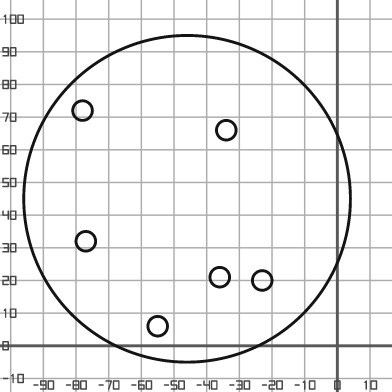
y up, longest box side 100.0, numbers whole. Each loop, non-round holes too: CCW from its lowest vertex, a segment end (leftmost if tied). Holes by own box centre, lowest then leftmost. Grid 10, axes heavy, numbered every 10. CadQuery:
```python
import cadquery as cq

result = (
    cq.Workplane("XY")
    .moveTo(-46.0, 45.0)
    .circle(50.0)
    .moveTo(-55.0, 6.0)
    .circle(3.0)
    .moveTo(-23.0, 20.0)
    .circle(3.0)
    .moveTo(-36.0, 21.0)
    .circle(3.0)
    .moveTo(-77.0, 32.0)
    .circle(3.0)
    .moveTo(-34.0, 66.0)
    .circle(3.0)
    .moveTo(-78.0, 72.0)
    .circle(3.0)
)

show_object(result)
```